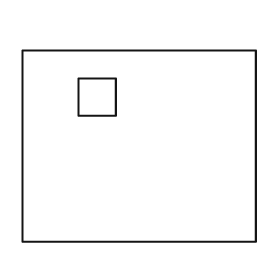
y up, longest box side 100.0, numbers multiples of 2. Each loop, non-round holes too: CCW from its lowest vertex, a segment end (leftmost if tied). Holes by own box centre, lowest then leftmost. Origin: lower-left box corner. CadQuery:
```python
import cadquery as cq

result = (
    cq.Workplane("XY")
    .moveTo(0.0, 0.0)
    .lineTo(100.0, 0.0)
    .lineTo(100.0, 82.0)
    .lineTo(0.0, 82.0)
    .close()
    .moveTo(24.0, 54.0)
    .lineTo(40.0, 54.0)
    .lineTo(40.0, 70.0)
    .lineTo(24.0, 70.0)
    .close()
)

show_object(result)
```